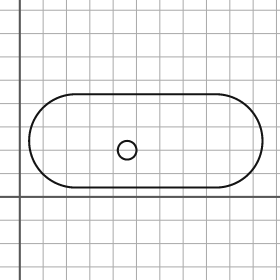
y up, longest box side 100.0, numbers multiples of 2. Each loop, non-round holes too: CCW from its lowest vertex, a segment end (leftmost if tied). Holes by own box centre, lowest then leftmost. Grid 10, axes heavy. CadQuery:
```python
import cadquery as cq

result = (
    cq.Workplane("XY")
    .moveTo(24.0, 4.0)
    .lineTo(84.0, 4.0)
    .threePointArc((104.0, 24.0), (84.0, 44.0))
    .lineTo(24.0, 44.0)
    .threePointArc((4.0, 24.0), (24.0, 4.0))
    .close()
    .moveTo(46.0, 20.0)
    .circle(4.0)
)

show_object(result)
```